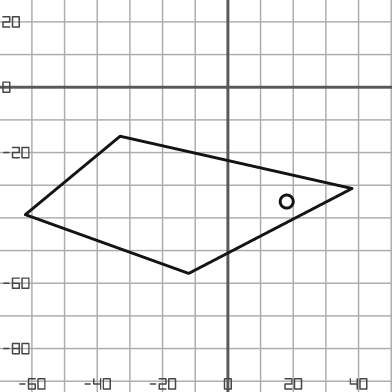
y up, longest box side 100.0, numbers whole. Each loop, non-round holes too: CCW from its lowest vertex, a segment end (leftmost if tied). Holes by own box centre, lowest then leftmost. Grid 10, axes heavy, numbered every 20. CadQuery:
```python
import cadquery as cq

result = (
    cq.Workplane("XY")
    .moveTo(-12.0, -57.0)
    .lineTo(38.0, -31.0)
    .lineTo(-33.0, -15.0)
    .lineTo(-62.0, -39.0)
    .close()
    .moveTo(18.0, -35.0)
    .circle(2.0)
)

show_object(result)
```